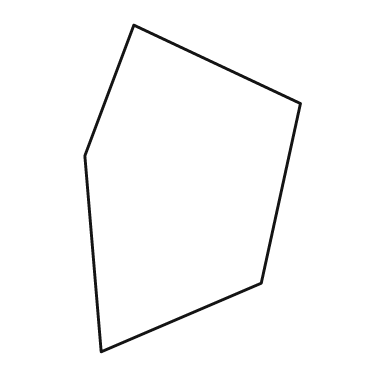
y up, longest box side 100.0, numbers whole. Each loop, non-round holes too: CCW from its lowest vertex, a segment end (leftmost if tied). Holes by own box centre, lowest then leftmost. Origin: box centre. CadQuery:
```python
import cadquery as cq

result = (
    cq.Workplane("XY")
    .moveTo(-28.0, -50.0)
    .lineTo(21.0, -29.0)
    .lineTo(33.0, 26.0)
    .lineTo(-18.0, 50.0)
    .lineTo(-33.0, 10.0)
    .close()
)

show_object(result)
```